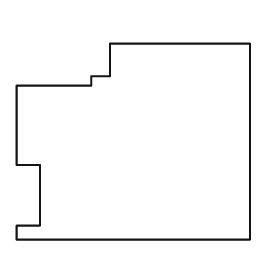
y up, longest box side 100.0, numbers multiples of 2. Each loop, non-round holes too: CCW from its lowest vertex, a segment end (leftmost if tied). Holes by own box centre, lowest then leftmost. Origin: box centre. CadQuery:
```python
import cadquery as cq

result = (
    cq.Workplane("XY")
    .moveTo(-50.0, -42.0)
    .lineTo(50.0, -42.0)
    .lineTo(50.0, 42.0)
    .lineTo(-10.0, 42.0)
    .lineTo(-10.0, 28.0)
    .lineTo(-18.0, 28.0)
    .lineTo(-18.0, 24.0)
    .lineTo(-50.0, 24.0)
    .lineTo(-50.0, -10.0)
    .lineTo(-40.0, -10.0)
    .lineTo(-40.0, -36.0)
    .lineTo(-50.0, -36.0)
    .close()
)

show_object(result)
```